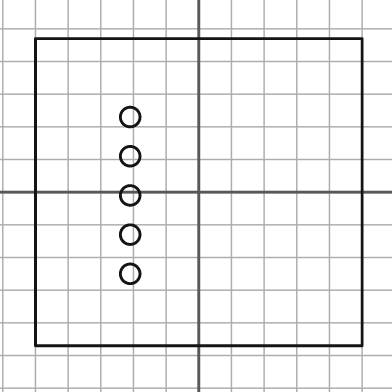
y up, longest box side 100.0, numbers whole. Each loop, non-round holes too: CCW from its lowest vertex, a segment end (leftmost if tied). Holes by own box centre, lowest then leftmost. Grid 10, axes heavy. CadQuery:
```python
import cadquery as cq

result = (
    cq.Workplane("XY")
    .moveTo(-50.0, -47.0)
    .lineTo(50.0, -47.0)
    .lineTo(50.0, 47.0)
    .lineTo(-50.0, 47.0)
    .close()
    .moveTo(-21.0, -25.0)
    .circle(3.0)
    .moveTo(-21.0, -13.0)
    .circle(3.0)
    .moveTo(-21.0, -1.0)
    .circle(3.0)
    .moveTo(-21.0, 11.0)
    .circle(3.0)
    .moveTo(-21.0, 23.0)
    .circle(3.0)
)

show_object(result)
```